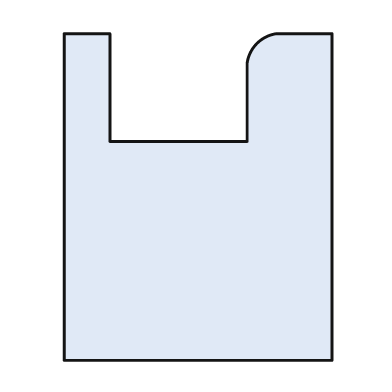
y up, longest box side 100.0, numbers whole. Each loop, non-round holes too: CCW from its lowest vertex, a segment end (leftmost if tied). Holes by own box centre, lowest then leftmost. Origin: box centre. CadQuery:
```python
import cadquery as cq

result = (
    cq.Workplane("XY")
    .moveTo(-41.0, -50.0)
    .lineTo(41.0, -50.0)
    .lineTo(41.0, 50.0)
    .lineTo(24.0, 50.0)
    .threePointArc((18.0, 47.0), (15.0, 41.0))
    .lineTo(15.0, 17.0)
    .lineTo(-27.0, 17.0)
    .lineTo(-27.0, 50.0)
    .lineTo(-41.0, 50.0)
    .close()
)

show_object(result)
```